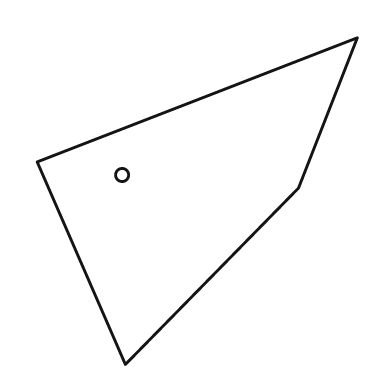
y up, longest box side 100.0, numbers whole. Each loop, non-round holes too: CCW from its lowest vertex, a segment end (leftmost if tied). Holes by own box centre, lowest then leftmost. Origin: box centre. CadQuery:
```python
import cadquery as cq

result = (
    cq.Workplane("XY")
    .moveTo(-22.0, -50.0)
    .lineTo(31.0, 4.0)
    .lineTo(49.0, 50.0)
    .lineTo(-49.0, 12.0)
    .close()
    .moveTo(-23.0, 8.0)
    .circle(2.0)
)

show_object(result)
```